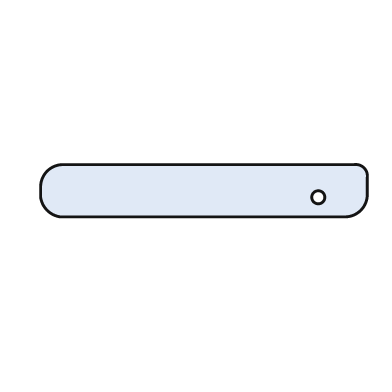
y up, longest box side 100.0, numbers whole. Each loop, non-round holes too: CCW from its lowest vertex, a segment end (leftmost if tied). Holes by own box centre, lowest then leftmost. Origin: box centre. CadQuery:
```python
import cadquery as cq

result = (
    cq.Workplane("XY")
    .moveTo(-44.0, -8.0)
    .lineTo(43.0, -8.0)
    .threePointArc((48.0, -6.0), (50.0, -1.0))
    .lineTo(50.0, 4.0)
    .threePointArc((49.0, 7.0), (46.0, 8.0))
    .lineTo(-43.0, 8.0)
    .threePointArc((-48.0, 6.0), (-50.0, 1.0))
    .lineTo(-50.0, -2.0)
    .threePointArc((-48.0, -6.0), (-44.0, -8.0))
    .close()
    .moveTo(35.0, -2.0)
    .circle(2.0)
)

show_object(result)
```